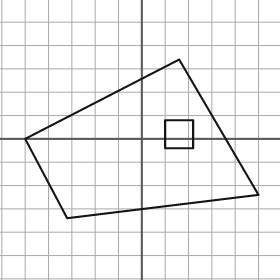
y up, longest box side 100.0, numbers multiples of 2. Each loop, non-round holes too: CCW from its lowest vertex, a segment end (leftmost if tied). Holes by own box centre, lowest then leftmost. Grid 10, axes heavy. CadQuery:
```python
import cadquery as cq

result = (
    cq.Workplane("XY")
    .moveTo(-32.0, -34.0)
    .lineTo(50.0, -24.0)
    .lineTo(16.0, 34.0)
    .lineTo(-50.0, 0.0)
    .close()
    .moveTo(10.0, -4.0)
    .lineTo(22.0, -4.0)
    .lineTo(22.0, 8.0)
    .lineTo(10.0, 8.0)
    .close()
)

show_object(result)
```